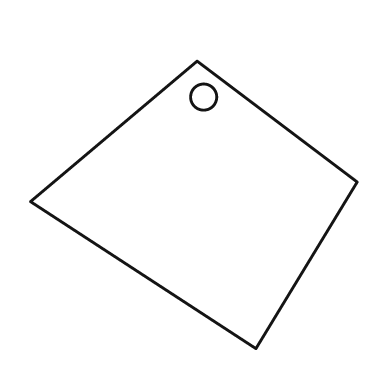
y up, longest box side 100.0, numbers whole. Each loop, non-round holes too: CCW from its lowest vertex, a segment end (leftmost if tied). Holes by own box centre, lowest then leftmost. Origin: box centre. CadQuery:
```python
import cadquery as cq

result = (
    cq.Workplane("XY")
    .moveTo(19.0, -44.0)
    .lineTo(50.0, 7.0)
    .lineTo(1.0, 44.0)
    .lineTo(-50.0, 1.0)
    .close()
    .moveTo(3.0, 33.0)
    .circle(4.0)
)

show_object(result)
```